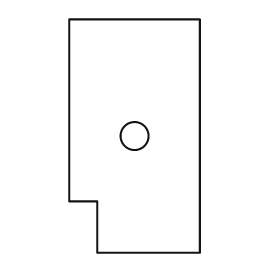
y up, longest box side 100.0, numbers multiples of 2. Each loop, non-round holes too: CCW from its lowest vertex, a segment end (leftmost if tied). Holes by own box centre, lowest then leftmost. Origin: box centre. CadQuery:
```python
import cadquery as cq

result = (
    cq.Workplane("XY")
    .moveTo(-16.0, -50.0)
    .lineTo(28.0, -50.0)
    .lineTo(28.0, 50.0)
    .lineTo(-28.0, 50.0)
    .lineTo(-28.0, -28.0)
    .lineTo(-16.0, -28.0)
    .close()
    .moveTo(0.0, 0.0)
    .circle(6.0)
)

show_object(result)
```